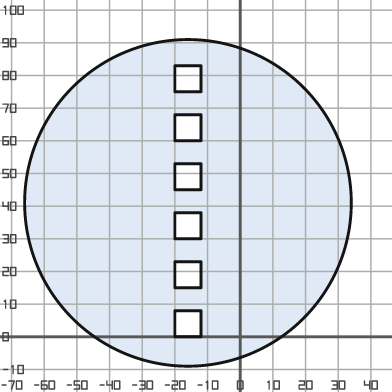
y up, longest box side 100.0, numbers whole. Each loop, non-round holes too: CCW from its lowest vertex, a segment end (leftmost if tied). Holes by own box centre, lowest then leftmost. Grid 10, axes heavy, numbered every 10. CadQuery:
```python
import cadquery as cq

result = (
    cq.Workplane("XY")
    .moveTo(-16.0, 41.0)
    .circle(50.0)
    .moveTo(-20.0, 0.0)
    .lineTo(-12.0, 0.0)
    .lineTo(-12.0, 8.0)
    .lineTo(-20.0, 8.0)
    .close()
    .moveTo(-20.0, 15.0)
    .lineTo(-12.0, 15.0)
    .lineTo(-12.0, 23.0)
    .lineTo(-20.0, 23.0)
    .close()
    .moveTo(-20.0, 30.0)
    .lineTo(-12.0, 30.0)
    .lineTo(-12.0, 38.0)
    .lineTo(-20.0, 38.0)
    .close()
    .moveTo(-20.0, 45.0)
    .lineTo(-12.0, 45.0)
    .lineTo(-12.0, 53.0)
    .lineTo(-20.0, 53.0)
    .close()
    .moveTo(-20.0, 60.0)
    .lineTo(-12.0, 60.0)
    .lineTo(-12.0, 68.0)
    .lineTo(-20.0, 68.0)
    .close()
    .moveTo(-20.0, 75.0)
    .lineTo(-12.0, 75.0)
    .lineTo(-12.0, 83.0)
    .lineTo(-20.0, 83.0)
    .close()
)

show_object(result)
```